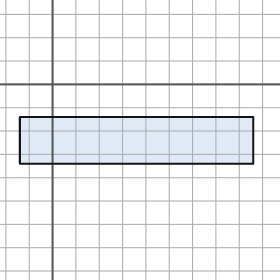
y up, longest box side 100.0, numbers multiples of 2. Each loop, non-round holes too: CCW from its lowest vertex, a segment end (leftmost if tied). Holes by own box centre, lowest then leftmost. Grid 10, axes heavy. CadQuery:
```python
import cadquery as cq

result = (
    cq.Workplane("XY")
    .moveTo(-14.0, -34.0)
    .lineTo(86.0, -34.0)
    .lineTo(86.0, -14.0)
    .lineTo(-14.0, -14.0)
    .close()
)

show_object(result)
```